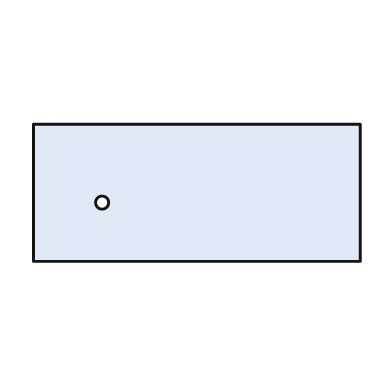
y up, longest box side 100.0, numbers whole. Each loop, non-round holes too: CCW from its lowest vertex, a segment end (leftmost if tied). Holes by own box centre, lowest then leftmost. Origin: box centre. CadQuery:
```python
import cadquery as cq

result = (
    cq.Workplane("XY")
    .moveTo(-50.0, -21.0)
    .lineTo(50.0, -21.0)
    .lineTo(50.0, 21.0)
    .lineTo(-50.0, 21.0)
    .close()
    .moveTo(-29.0, -3.0)
    .circle(2.0)
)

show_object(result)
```